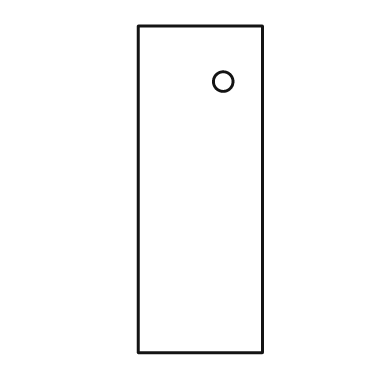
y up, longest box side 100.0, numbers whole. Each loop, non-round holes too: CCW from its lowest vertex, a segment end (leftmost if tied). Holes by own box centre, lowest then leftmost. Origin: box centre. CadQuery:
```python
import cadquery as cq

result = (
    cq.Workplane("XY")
    .moveTo(-19.0, -50.0)
    .lineTo(19.0, -50.0)
    .lineTo(19.0, 50.0)
    .lineTo(-19.0, 50.0)
    .close()
    .moveTo(7.0, 33.0)
    .circle(3.0)
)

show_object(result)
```